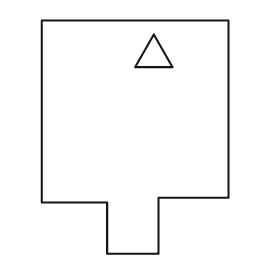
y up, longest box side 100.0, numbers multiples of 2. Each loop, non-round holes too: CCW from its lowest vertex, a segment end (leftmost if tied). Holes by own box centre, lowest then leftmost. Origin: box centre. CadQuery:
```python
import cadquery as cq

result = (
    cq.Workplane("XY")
    .moveTo(-12.0, -50.0)
    .lineTo(10.0, -50.0)
    .lineTo(10.0, -26.0)
    .lineTo(40.0, -26.0)
    .lineTo(40.0, 50.0)
    .lineTo(-40.0, 50.0)
    .lineTo(-40.0, -28.0)
    .lineTo(-12.0, -28.0)
    .close()
    .moveTo(0.0, 30.0)
    .lineTo(16.0, 30.0)
    .lineTo(8.0, 44.0)
    .close()
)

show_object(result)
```